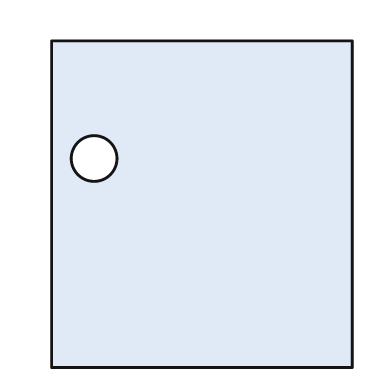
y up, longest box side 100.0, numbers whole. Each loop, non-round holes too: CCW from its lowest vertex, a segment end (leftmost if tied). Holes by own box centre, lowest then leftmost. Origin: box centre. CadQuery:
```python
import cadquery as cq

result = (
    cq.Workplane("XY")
    .moveTo(-46.0, -50.0)
    .lineTo(46.0, -50.0)
    .lineTo(46.0, 50.0)
    .lineTo(-46.0, 50.0)
    .close()
    .moveTo(-33.0, 14.0)
    .circle(7.0)
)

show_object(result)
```